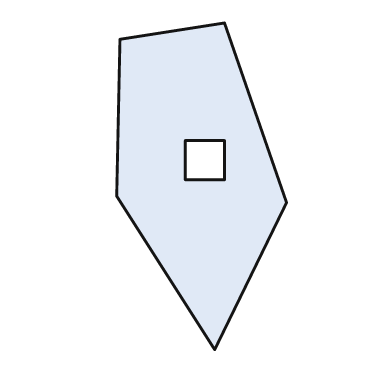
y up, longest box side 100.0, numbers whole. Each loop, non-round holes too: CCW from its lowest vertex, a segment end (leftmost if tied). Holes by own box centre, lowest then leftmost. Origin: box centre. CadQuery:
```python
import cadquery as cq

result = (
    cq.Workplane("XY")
    .moveTo(4.0, -50.0)
    .lineTo(26.0, -5.0)
    .lineTo(7.0, 50.0)
    .lineTo(-25.0, 45.0)
    .lineTo(-26.0, -3.0)
    .close()
    .moveTo(-5.0, 2.0)
    .lineTo(7.0, 2.0)
    .lineTo(7.0, 14.0)
    .lineTo(-5.0, 14.0)
    .close()
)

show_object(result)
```